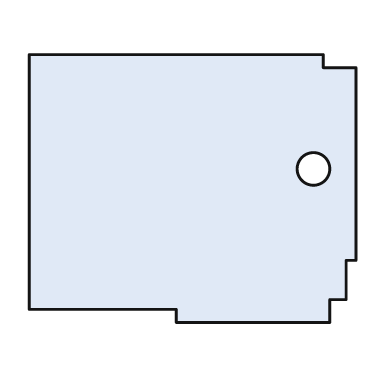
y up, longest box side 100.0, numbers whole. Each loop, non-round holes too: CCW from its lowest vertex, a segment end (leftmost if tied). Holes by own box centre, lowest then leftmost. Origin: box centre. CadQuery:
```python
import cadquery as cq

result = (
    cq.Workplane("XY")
    .moveTo(-5.0, -41.0)
    .lineTo(42.0, -41.0)
    .lineTo(42.0, -34.0)
    .lineTo(47.0, -34.0)
    .lineTo(47.0, -22.0)
    .lineTo(50.0, -22.0)
    .lineTo(50.0, 37.0)
    .lineTo(40.0, 37.0)
    .lineTo(40.0, 41.0)
    .lineTo(-50.0, 41.0)
    .lineTo(-50.0, -37.0)
    .lineTo(-5.0, -37.0)
    .close()
    .moveTo(37.0, 6.0)
    .circle(5.0)
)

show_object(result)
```